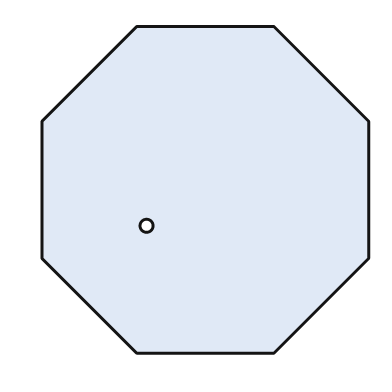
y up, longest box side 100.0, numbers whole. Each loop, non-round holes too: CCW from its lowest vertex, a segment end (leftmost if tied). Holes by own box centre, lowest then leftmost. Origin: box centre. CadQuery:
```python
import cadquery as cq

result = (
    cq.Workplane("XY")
    .moveTo(-21.0, -50.0)
    .lineTo(21.0, -50.0)
    .lineTo(50.0, -21.0)
    .lineTo(50.0, 21.0)
    .lineTo(21.0, 50.0)
    .lineTo(-21.0, 50.0)
    .lineTo(-50.0, 21.0)
    .lineTo(-50.0, -21.0)
    .close()
    .moveTo(-18.0, -11.0)
    .circle(2.0)
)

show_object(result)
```